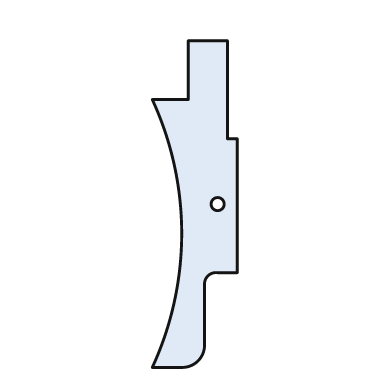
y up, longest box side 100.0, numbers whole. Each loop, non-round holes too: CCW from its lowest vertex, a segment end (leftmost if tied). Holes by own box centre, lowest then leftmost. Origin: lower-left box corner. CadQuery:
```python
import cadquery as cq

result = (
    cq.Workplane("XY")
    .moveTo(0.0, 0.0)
    .lineTo(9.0, 0.0)
    .threePointArc((14.0, 2.0), (16.0, 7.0))
    .lineTo(16.0, 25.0)
    .threePointArc((17.0, 28.0), (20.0, 29.0))
    .lineTo(26.0, 29.0)
    .lineTo(26.0, 70.0)
    .lineTo(23.0, 70.0)
    .lineTo(23.0, 100.0)
    .lineTo(11.0, 100.0)
    .lineTo(11.0, 82.0)
    .lineTo(0.0, 82.0)
    .threePointArc((9.0, 41.0), (0.0, 0.0))
    .close()
    .moveTo(20.0, 50.0)
    .circle(2.0)
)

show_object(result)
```